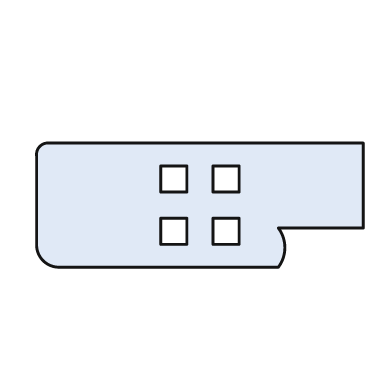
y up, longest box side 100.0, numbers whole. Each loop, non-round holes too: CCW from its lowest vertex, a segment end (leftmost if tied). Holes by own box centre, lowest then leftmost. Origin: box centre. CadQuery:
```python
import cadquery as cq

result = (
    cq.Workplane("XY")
    .moveTo(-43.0, -19.0)
    .lineTo(24.0, -19.0)
    .threePointArc((26.0, -13.0), (24.0, -7.0))
    .lineTo(50.0, -7.0)
    .lineTo(50.0, 19.0)
    .lineTo(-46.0, 19.0)
    .threePointArc((-49.0, 18.0), (-50.0, 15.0))
    .lineTo(-50.0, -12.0)
    .threePointArc((-48.0, -17.0), (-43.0, -19.0))
    .close()
    .moveTo(-12.0, -12.0)
    .lineTo(-4.0, -12.0)
    .lineTo(-4.0, -4.0)
    .lineTo(-12.0, -4.0)
    .close()
    .moveTo(4.0, -12.0)
    .lineTo(12.0, -12.0)
    .lineTo(12.0, -4.0)
    .lineTo(4.0, -4.0)
    .close()
    .moveTo(-12.0, 4.0)
    .lineTo(-4.0, 4.0)
    .lineTo(-4.0, 12.0)
    .lineTo(-12.0, 12.0)
    .close()
    .moveTo(4.0, 4.0)
    .lineTo(12.0, 4.0)
    .lineTo(12.0, 12.0)
    .lineTo(4.0, 12.0)
    .close()
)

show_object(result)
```